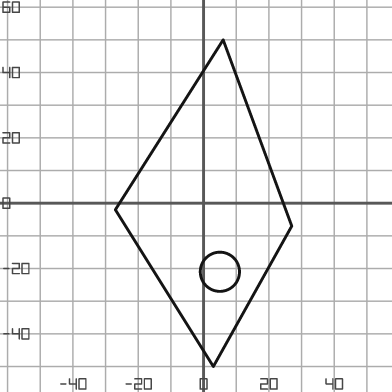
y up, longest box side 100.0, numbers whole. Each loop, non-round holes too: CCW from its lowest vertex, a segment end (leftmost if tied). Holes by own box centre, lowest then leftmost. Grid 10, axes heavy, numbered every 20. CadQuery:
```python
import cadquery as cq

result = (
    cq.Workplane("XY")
    .moveTo(3.0, -50.0)
    .lineTo(27.0, -7.0)
    .lineTo(6.0, 50.0)
    .lineTo(-27.0, -2.0)
    .close()
    .moveTo(5.0, -21.0)
    .circle(6.0)
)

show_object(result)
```